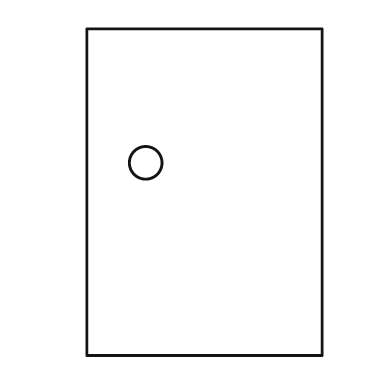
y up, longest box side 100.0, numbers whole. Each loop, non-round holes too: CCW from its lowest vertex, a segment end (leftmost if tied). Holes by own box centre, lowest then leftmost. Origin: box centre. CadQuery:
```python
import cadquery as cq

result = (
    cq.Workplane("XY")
    .moveTo(-36.0, -50.0)
    .lineTo(36.0, -50.0)
    .lineTo(36.0, 50.0)
    .lineTo(-36.0, 50.0)
    .close()
    .moveTo(-18.0, 9.0)
    .circle(5.0)
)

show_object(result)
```